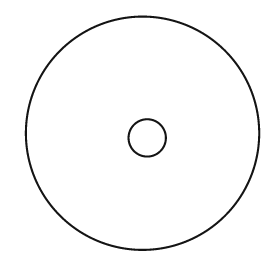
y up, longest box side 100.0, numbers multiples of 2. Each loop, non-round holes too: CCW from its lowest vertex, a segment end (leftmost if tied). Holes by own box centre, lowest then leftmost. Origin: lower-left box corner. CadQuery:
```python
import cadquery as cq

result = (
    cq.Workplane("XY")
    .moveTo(50.0, 50.0)
    .circle(50.0)
    .moveTo(52.0, 48.0)
    .circle(8.0)
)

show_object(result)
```